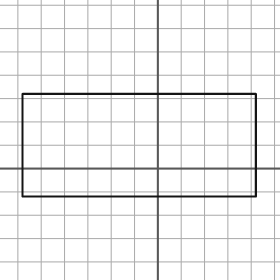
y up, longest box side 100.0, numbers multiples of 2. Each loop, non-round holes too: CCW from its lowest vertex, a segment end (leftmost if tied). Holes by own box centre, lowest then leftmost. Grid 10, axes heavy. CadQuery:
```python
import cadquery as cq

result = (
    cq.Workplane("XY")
    .moveTo(-58.0, -12.0)
    .lineTo(42.0, -12.0)
    .lineTo(42.0, 32.0)
    .lineTo(-58.0, 32.0)
    .close()
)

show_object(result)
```